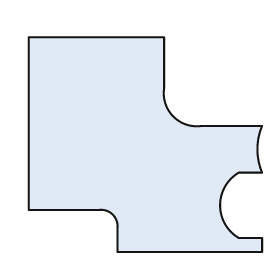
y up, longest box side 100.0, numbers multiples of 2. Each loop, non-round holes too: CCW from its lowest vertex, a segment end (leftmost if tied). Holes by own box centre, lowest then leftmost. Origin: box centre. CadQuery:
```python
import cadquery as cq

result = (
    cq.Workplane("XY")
    .moveTo(-12.0, -46.0)
    .lineTo(50.0, -46.0)
    .lineTo(50.0, -40.0)
    .lineTo(40.0, -40.0)
    .threePointArc((32.0, -26.0), (40.0, -12.0))
    .lineTo(50.0, -12.0)
    .threePointArc((48.0, -2.0), (50.0, 8.0))
    .lineTo(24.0, 8.0)
    .threePointArc((12.0, 12.0), (8.0, 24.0))
    .lineTo(8.0, 46.0)
    .lineTo(-50.0, 46.0)
    .lineTo(-50.0, -28.0)
    .lineTo(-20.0, -28.0)
    .threePointArc((-14.0, -30.0), (-12.0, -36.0))
    .close()
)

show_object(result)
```